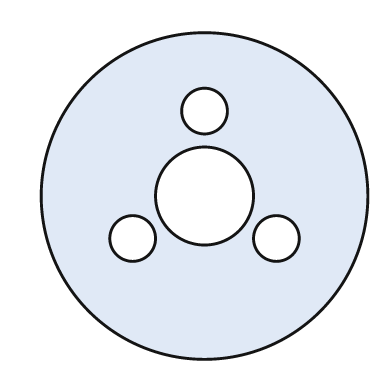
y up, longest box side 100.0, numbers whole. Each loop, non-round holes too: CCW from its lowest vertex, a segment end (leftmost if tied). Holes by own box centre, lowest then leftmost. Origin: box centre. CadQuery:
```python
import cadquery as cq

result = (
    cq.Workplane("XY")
    .moveTo(0.0, 0.0)
    .circle(50.0)
    .moveTo(-22.0, -13.0)
    .circle(7.0)
    .moveTo(22.0, -13.0)
    .circle(7.0)
    .moveTo(0.0, 0.0)
    .circle(15.0)
    .moveTo(0.0, 26.0)
    .circle(7.0)
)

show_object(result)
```